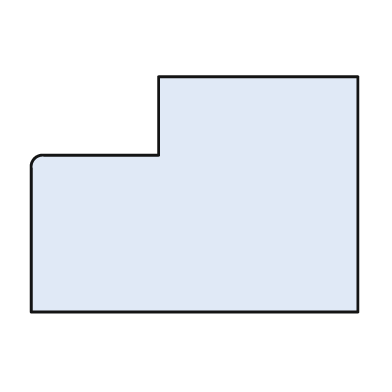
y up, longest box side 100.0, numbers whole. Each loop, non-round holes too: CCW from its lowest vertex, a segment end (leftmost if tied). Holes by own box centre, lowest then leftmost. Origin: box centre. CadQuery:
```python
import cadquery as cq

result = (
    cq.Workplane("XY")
    .moveTo(-50.0, -36.0)
    .lineTo(50.0, -36.0)
    .lineTo(50.0, 36.0)
    .lineTo(-11.0, 36.0)
    .lineTo(-11.0, 12.0)
    .lineTo(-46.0, 12.0)
    .threePointArc((-49.0, 11.0), (-50.0, 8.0))
    .close()
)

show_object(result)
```